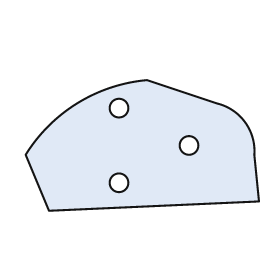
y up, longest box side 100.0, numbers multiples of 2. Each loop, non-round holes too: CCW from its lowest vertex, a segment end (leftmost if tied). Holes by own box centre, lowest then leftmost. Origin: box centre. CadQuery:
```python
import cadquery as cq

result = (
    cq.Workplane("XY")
    .moveTo(-40.0, -28.0)
    .lineTo(50.0, -24.0)
    .lineTo(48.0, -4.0)
    .threePointArc((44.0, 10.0), (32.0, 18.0))
    .lineTo(2.0, 28.0)
    .threePointArc((-28.0, 18.0), (-50.0, -4.0))
    .close()
    .moveTo(-10.0, -16.0)
    .circle(4.0)
    .moveTo(20.0, 0.0)
    .circle(4.0)
    .moveTo(-10.0, 16.0)
    .circle(4.0)
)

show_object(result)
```